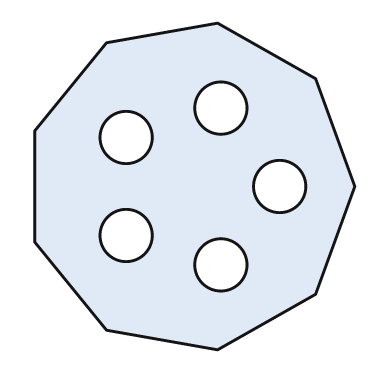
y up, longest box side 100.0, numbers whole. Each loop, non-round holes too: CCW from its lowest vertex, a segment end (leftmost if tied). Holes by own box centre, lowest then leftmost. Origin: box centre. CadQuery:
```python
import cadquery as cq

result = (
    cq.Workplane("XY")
    .moveTo(7.0, -50.0)
    .lineTo(37.0, -33.0)
    .lineTo(49.0, 0.0)
    .lineTo(37.0, 33.0)
    .lineTo(7.0, 50.0)
    .lineTo(-27.0, 44.0)
    .lineTo(-49.0, 17.0)
    .lineTo(-49.0, -17.0)
    .lineTo(-27.0, -44.0)
    .close()
    .moveTo(8.0, -24.0)
    .circle(8.0)
    .moveTo(-21.0, -15.0)
    .circle(8.0)
    .moveTo(26.0, 0.0)
    .circle(8.0)
    .moveTo(-21.0, 15.0)
    .circle(8.0)
    .moveTo(8.0, 24.0)
    .circle(8.0)
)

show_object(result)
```